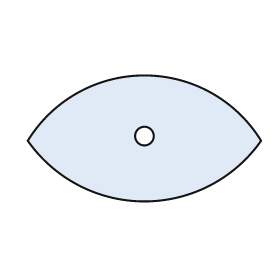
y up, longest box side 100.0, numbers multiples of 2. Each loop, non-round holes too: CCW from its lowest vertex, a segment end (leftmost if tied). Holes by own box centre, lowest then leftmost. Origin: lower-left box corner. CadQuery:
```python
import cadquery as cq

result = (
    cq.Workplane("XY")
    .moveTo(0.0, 26.0)
    .threePointArc((50.0, 0.0), (100.0, 26.0))
    .threePointArc((50.0, 54.0), (0.0, 26.0))
    .close()
    .moveTo(50.0, 28.0)
    .circle(4.0)
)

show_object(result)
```